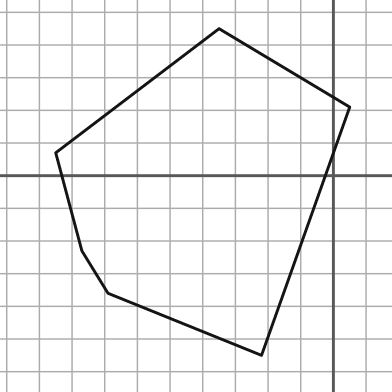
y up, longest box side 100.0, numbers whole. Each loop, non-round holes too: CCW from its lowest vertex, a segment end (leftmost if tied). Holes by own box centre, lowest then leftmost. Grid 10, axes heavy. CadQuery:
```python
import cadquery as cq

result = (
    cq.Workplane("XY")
    .moveTo(-22.0, -55.0)
    .lineTo(5.0, 21.0)
    .lineTo(-35.0, 45.0)
    .lineTo(-85.0, 7.0)
    .lineTo(-77.0, -23.0)
    .lineTo(-69.0, -36.0)
    .close()
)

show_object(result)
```